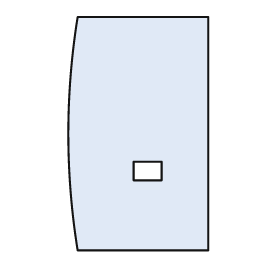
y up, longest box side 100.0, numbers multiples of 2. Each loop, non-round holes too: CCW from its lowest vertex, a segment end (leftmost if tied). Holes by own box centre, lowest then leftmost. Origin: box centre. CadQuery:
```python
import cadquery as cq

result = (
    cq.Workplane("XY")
    .moveTo(-26.0, -50.0)
    .lineTo(30.0, -50.0)
    .lineTo(30.0, 50.0)
    .lineTo(-26.0, 50.0)
    .threePointArc((-30.0, 0.0), (-26.0, -50.0))
    .close()
    .moveTo(-2.0, -20.0)
    .lineTo(10.0, -20.0)
    .lineTo(10.0, -12.0)
    .lineTo(-2.0, -12.0)
    .close()
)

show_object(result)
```